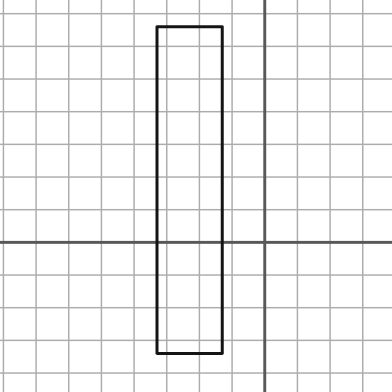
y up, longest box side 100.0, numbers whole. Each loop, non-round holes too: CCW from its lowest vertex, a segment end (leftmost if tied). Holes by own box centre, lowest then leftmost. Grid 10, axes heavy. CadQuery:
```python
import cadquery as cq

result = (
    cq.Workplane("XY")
    .moveTo(-33.0, -34.0)
    .lineTo(-13.0, -34.0)
    .lineTo(-13.0, 66.0)
    .lineTo(-33.0, 66.0)
    .close()
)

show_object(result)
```